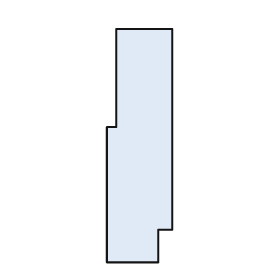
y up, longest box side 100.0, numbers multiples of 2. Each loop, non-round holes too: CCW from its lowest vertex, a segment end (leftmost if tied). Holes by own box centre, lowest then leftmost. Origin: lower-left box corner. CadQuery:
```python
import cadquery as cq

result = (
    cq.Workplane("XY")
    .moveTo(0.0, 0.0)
    .lineTo(22.0, 0.0)
    .lineTo(22.0, 14.0)
    .lineTo(28.0, 14.0)
    .lineTo(28.0, 100.0)
    .lineTo(4.0, 100.0)
    .lineTo(4.0, 58.0)
    .lineTo(0.0, 58.0)
    .close()
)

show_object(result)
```